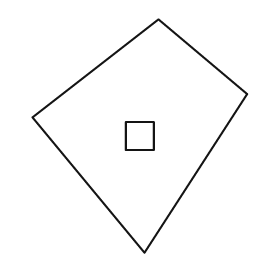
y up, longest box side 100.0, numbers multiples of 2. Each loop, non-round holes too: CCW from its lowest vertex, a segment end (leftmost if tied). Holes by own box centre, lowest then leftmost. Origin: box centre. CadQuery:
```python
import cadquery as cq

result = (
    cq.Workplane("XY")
    .moveTo(2.0, -50.0)
    .lineTo(46.0, 18.0)
    .lineTo(8.0, 50.0)
    .lineTo(-46.0, 8.0)
    .close()
    .moveTo(-6.0, -6.0)
    .lineTo(6.0, -6.0)
    .lineTo(6.0, 6.0)
    .lineTo(-6.0, 6.0)
    .close()
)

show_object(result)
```